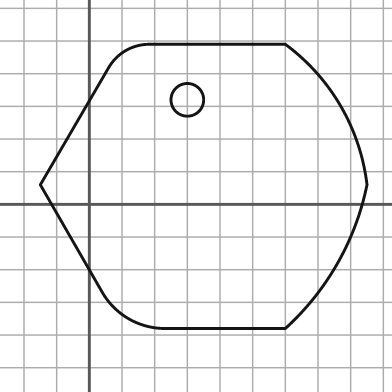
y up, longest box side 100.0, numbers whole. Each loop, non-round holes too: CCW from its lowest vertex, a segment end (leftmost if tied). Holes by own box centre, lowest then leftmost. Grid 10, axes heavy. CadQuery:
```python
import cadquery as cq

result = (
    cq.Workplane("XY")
    .moveTo(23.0, -38.0)
    .lineTo(60.0, -38.0)
    .threePointArc((76.0, -18.0), (85.0, 6.0))
    .threePointArc((77.0, 30.0), (60.0, 49.0))
    .lineTo(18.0, 49.0)
    .threePointArc((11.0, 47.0), (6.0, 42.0))
    .lineTo(-15.0, 6.0)
    .lineTo(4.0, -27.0)
    .threePointArc((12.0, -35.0), (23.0, -38.0))
    .close()
    .moveTo(30.0, 32.0)
    .circle(5.0)
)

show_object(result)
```